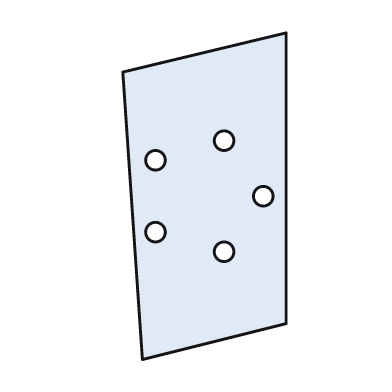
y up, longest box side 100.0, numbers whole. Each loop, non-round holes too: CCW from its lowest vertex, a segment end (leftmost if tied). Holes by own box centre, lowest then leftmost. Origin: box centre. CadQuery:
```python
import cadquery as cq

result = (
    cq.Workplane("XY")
    .moveTo(-19.0, -50.0)
    .lineTo(25.0, -39.0)
    .lineTo(25.0, 50.0)
    .lineTo(-25.0, 38.0)
    .close()
    .moveTo(6.0, -17.0)
    .circle(3.0)
    .moveTo(-15.0, -11.0)
    .circle(3.0)
    .moveTo(18.0, 0.0)
    .circle(3.0)
    .moveTo(-15.0, 11.0)
    .circle(3.0)
    .moveTo(6.0, 17.0)
    .circle(3.0)
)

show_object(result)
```